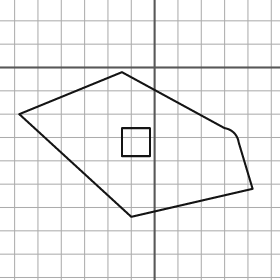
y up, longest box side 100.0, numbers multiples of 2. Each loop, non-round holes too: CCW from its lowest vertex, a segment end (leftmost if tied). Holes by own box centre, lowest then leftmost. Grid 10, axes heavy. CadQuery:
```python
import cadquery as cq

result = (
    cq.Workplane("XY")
    .moveTo(-10.0, -64.0)
    .lineTo(42.0, -52.0)
    .lineTo(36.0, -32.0)
    .threePointArc((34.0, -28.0), (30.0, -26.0))
    .lineTo(-14.0, -2.0)
    .lineTo(-58.0, -20.0)
    .close()
    .moveTo(-14.0, -38.0)
    .lineTo(-2.0, -38.0)
    .lineTo(-2.0, -26.0)
    .lineTo(-14.0, -26.0)
    .close()
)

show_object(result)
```